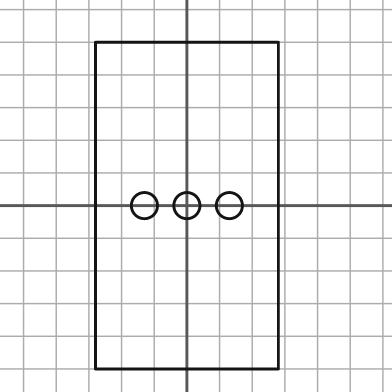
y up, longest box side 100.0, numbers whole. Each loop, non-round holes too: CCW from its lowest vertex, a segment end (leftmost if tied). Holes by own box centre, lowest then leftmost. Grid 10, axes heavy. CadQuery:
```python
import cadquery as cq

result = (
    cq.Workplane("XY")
    .moveTo(-28.0, -50.0)
    .lineTo(28.0, -50.0)
    .lineTo(28.0, 50.0)
    .lineTo(-28.0, 50.0)
    .close()
    .moveTo(-13.0, 0.0)
    .circle(4.0)
    .moveTo(0.0, 0.0)
    .circle(4.0)
    .moveTo(13.0, 0.0)
    .circle(4.0)
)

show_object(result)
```